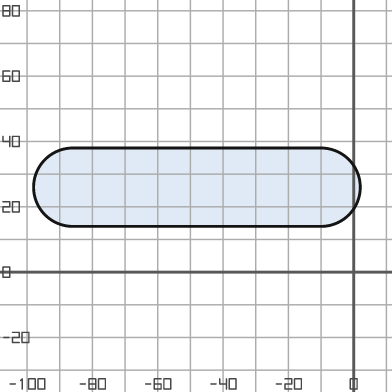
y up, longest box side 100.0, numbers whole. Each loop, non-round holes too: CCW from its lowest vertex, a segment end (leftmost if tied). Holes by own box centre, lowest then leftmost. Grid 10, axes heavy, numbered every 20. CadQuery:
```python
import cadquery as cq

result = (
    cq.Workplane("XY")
    .moveTo(-86.0, 14.0)
    .lineTo(-10.0, 14.0)
    .threePointArc((2.0, 26.0), (-10.0, 38.0))
    .lineTo(-86.0, 38.0)
    .threePointArc((-98.0, 26.0), (-86.0, 14.0))
    .close()
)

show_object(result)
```